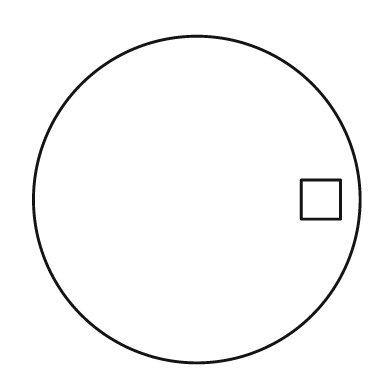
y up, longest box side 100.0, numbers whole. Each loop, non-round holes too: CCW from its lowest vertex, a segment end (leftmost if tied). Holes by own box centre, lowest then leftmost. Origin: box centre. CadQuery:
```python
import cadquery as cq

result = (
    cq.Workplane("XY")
    .moveTo(0.0, 0.0)
    .circle(50.0)
    .moveTo(32.0, -6.0)
    .lineTo(44.0, -6.0)
    .lineTo(44.0, 6.0)
    .lineTo(32.0, 6.0)
    .close()
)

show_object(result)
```